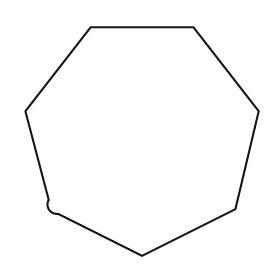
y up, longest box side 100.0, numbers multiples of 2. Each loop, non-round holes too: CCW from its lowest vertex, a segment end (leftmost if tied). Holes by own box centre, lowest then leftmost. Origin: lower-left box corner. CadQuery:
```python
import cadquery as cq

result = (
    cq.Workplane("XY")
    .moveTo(50.0, 0.0)
    .lineTo(90.0, 20.0)
    .lineTo(100.0, 62.0)
    .lineTo(72.0, 98.0)
    .lineTo(28.0, 98.0)
    .lineTo(0.0, 62.0)
    .lineTo(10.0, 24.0)
    .threePointArc((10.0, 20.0), (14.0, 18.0))
    .close()
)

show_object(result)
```